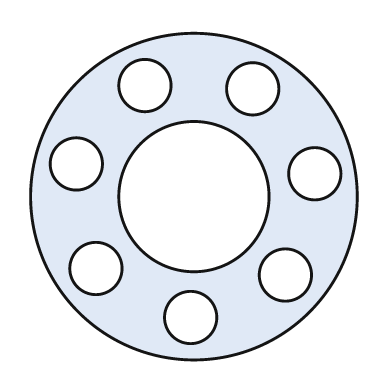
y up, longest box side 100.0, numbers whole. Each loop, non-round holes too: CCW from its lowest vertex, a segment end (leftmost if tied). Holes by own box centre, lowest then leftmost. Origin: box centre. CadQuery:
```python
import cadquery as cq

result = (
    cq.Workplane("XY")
    .moveTo(0.0, 0.0)
    .circle(50.0)
    .moveTo(-1.0, -37.0)
    .circle(8.0)
    .moveTo(28.0, -24.0)
    .circle(8.0)
    .moveTo(-30.0, -22.0)
    .circle(8.0)
    .moveTo(0.0, 0.0)
    .circle(23.0)
    .moveTo(37.0, 7.0)
    .circle(8.0)
    .moveTo(-36.0, 10.0)
    .circle(8.0)
    .moveTo(18.0, 33.0)
    .circle(8.0)
    .moveTo(-15.0, 34.0)
    .circle(8.0)
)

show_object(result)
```